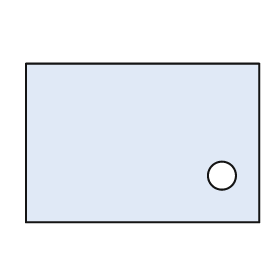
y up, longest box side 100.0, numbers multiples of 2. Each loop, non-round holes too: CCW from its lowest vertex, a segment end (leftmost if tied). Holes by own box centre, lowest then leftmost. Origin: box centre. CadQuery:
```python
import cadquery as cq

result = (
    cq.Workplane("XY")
    .moveTo(-50.0, -34.0)
    .lineTo(50.0, -34.0)
    .lineTo(50.0, 34.0)
    .lineTo(-50.0, 34.0)
    .close()
    .moveTo(34.0, -14.0)
    .circle(6.0)
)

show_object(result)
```